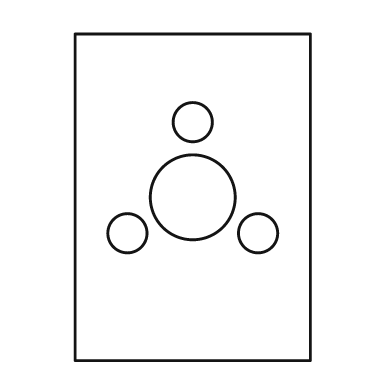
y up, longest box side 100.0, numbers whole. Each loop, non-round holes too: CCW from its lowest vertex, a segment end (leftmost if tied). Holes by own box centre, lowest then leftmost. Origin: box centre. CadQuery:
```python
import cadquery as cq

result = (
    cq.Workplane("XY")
    .moveTo(-36.0, -50.0)
    .lineTo(36.0, -50.0)
    .lineTo(36.0, 50.0)
    .lineTo(-36.0, 50.0)
    .close()
    .moveTo(-20.0, -11.0)
    .circle(6.0)
    .moveTo(20.0, -11.0)
    .circle(6.0)
    .moveTo(0.0, 0.0)
    .circle(13.0)
    .moveTo(0.0, 23.0)
    .circle(6.0)
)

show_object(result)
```